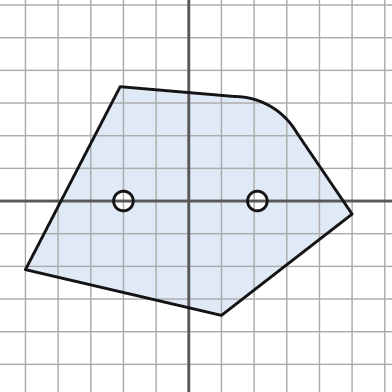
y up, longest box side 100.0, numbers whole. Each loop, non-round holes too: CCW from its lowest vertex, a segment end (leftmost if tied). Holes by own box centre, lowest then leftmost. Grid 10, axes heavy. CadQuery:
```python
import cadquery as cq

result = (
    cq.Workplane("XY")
    .moveTo(10.0, -35.0)
    .lineTo(50.0, -4.0)
    .lineTo(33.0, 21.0)
    .threePointArc((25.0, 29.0), (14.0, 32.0))
    .lineTo(-21.0, 35.0)
    .lineTo(-50.0, -21.0)
    .close()
    .moveTo(-20.0, 0.0)
    .circle(3.0)
    .moveTo(21.0, 0.0)
    .circle(3.0)
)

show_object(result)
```